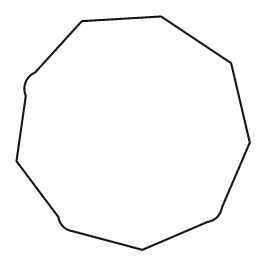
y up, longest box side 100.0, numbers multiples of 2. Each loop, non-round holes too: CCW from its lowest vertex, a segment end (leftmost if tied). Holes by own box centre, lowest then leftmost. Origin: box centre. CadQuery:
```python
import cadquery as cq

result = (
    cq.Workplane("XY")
    .moveTo(4.0, -50.0)
    .lineTo(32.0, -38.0)
    .threePointArc((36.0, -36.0), (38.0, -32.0))
    .lineTo(50.0, -4.0)
    .lineTo(42.0, 30.0)
    .lineTo(12.0, 50.0)
    .lineTo(-22.0, 48.0)
    .lineTo(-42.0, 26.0)
    .threePointArc((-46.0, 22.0), (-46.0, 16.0))
    .lineTo(-50.0, -12.0)
    .lineTo(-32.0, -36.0)
    .threePointArc((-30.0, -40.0), (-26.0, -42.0))
    .close()
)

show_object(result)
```